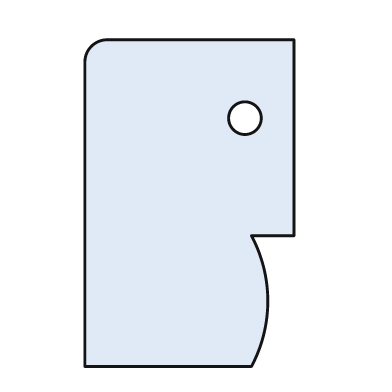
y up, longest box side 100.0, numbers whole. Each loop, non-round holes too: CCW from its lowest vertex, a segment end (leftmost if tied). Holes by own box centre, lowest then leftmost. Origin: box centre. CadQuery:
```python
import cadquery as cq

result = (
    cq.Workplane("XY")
    .moveTo(-32.0, -50.0)
    .lineTo(19.0, -50.0)
    .threePointArc((24.0, -30.0), (19.0, -10.0))
    .lineTo(32.0, -10.0)
    .lineTo(32.0, 50.0)
    .lineTo(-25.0, 50.0)
    .threePointArc((-30.0, 48.0), (-32.0, 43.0))
    .close()
    .moveTo(17.0, 26.0)
    .circle(5.0)
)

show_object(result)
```